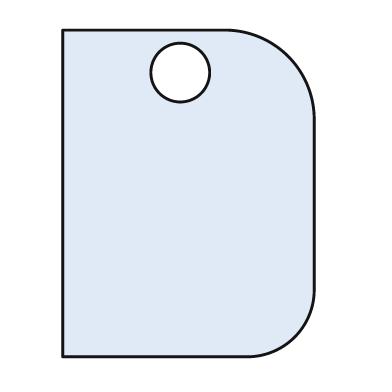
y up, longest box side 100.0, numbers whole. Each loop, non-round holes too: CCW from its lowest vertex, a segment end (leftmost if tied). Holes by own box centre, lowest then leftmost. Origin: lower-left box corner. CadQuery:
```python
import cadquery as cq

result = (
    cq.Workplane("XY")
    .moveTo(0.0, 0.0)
    .lineTo(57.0, 0.0)
    .threePointArc((71.0, 6.0), (77.0, 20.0))
    .lineTo(77.0, 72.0)
    .threePointArc((69.0, 92.0), (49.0, 100.0))
    .lineTo(0.0, 100.0)
    .close()
    .moveTo(36.0, 87.0)
    .circle(9.0)
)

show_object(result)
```